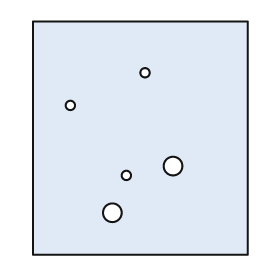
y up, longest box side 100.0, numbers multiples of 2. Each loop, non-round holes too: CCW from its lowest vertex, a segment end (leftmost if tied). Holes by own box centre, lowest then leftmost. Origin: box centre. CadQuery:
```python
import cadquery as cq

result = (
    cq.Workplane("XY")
    .moveTo(-46.0, -50.0)
    .lineTo(46.0, -50.0)
    .lineTo(46.0, 50.0)
    .lineTo(-46.0, 50.0)
    .close()
    .moveTo(-12.0, -32.0)
    .circle(4.0)
    .moveTo(-6.0, -16.0)
    .circle(2.0)
    .moveTo(14.0, -12.0)
    .circle(4.0)
    .moveTo(-30.0, 14.0)
    .circle(2.0)
    .moveTo(2.0, 28.0)
    .circle(2.0)
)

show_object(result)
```